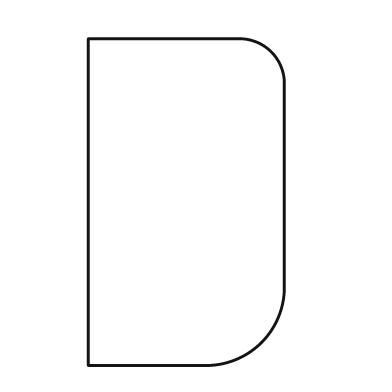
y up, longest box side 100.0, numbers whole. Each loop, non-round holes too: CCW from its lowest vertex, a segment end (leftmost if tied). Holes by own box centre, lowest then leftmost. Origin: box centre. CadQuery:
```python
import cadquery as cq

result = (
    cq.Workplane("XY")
    .moveTo(-30.0, -50.0)
    .lineTo(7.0, -50.0)
    .threePointArc((23.0, -43.0), (30.0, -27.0))
    .lineTo(30.0, 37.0)
    .threePointArc((26.0, 46.0), (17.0, 50.0))
    .lineTo(-30.0, 50.0)
    .close()
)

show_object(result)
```